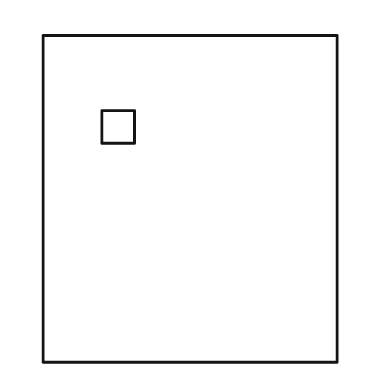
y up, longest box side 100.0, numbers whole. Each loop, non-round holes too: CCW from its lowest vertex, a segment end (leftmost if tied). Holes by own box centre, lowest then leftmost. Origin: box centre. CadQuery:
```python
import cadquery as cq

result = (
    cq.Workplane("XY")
    .moveTo(-45.0, -50.0)
    .lineTo(45.0, -50.0)
    .lineTo(45.0, 50.0)
    .lineTo(-45.0, 50.0)
    .close()
    .moveTo(-27.0, 17.0)
    .lineTo(-17.0, 17.0)
    .lineTo(-17.0, 27.0)
    .lineTo(-27.0, 27.0)
    .close()
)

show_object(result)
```